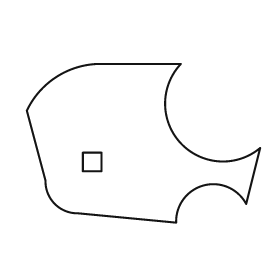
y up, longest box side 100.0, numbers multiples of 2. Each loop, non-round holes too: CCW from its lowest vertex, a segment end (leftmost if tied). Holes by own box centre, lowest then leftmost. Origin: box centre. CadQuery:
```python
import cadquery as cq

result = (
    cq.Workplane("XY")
    .moveTo(14.0, -34.0)
    .threePointArc((26.0, -18.0), (44.0, -26.0))
    .lineTo(50.0, -2.0)
    .threePointArc((16.0, 0.0), (16.0, 34.0))
    .lineTo(-20.0, 34.0)
    .threePointArc((-38.0, 28.0), (-50.0, 14.0))
    .lineTo(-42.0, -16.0)
    .threePointArc((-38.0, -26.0), (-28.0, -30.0))
    .close()
    .moveTo(-26.0, -12.0)
    .lineTo(-18.0, -12.0)
    .lineTo(-18.0, -4.0)
    .lineTo(-26.0, -4.0)
    .close()
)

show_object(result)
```